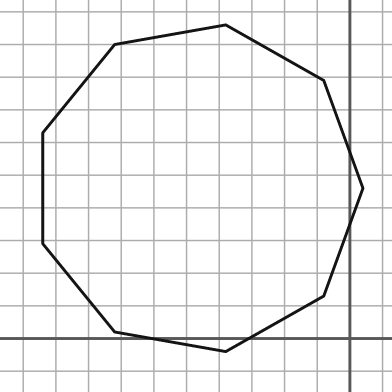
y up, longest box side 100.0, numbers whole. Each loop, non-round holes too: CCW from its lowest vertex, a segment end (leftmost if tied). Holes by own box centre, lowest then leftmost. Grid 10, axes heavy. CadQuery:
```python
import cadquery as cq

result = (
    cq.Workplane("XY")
    .moveTo(-38.0, -4.0)
    .lineTo(-8.0, 13.0)
    .lineTo(4.0, 46.0)
    .lineTo(-8.0, 79.0)
    .lineTo(-38.0, 96.0)
    .lineTo(-72.0, 90.0)
    .lineTo(-94.0, 63.0)
    .lineTo(-94.0, 29.0)
    .lineTo(-72.0, 2.0)
    .close()
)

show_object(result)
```